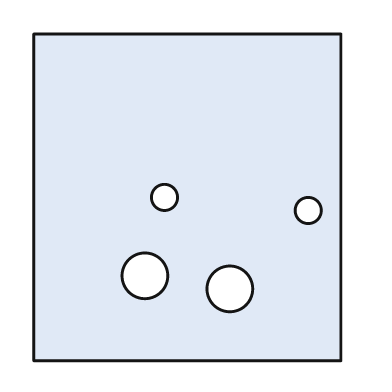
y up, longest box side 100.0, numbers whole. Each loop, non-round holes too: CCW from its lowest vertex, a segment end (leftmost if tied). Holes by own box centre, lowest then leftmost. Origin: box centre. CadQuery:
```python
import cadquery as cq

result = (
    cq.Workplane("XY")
    .moveTo(-47.0, -50.0)
    .lineTo(47.0, -50.0)
    .lineTo(47.0, 50.0)
    .lineTo(-47.0, 50.0)
    .close()
    .moveTo(13.0, -28.0)
    .circle(7.0)
    .moveTo(-13.0, -24.0)
    .circle(7.0)
    .moveTo(37.0, -4.0)
    .circle(4.0)
    .moveTo(-7.0, 0.0)
    .circle(4.0)
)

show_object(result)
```